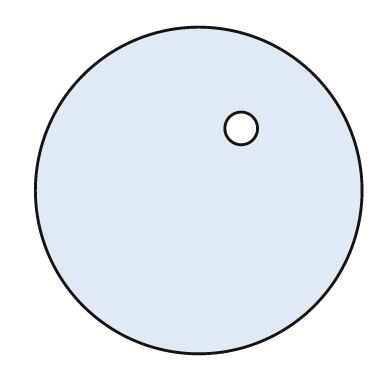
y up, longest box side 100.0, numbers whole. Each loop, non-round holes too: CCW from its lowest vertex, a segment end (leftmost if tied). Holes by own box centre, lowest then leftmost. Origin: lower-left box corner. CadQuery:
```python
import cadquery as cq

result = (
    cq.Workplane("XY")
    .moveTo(50.0, 50.0)
    .circle(50.0)
    .moveTo(63.0, 69.0)
    .circle(5.0)
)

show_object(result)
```